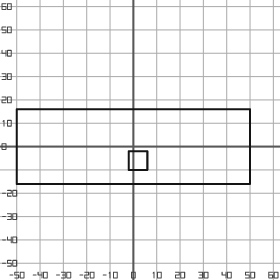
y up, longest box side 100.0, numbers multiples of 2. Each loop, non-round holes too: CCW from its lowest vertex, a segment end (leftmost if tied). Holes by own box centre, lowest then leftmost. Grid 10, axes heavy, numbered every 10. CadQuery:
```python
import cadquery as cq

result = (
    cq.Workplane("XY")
    .moveTo(-50.0, -16.0)
    .lineTo(50.0, -16.0)
    .lineTo(50.0, 16.0)
    .lineTo(-50.0, 16.0)
    .close()
    .moveTo(-2.0, -10.0)
    .lineTo(6.0, -10.0)
    .lineTo(6.0, -2.0)
    .lineTo(-2.0, -2.0)
    .close()
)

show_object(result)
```